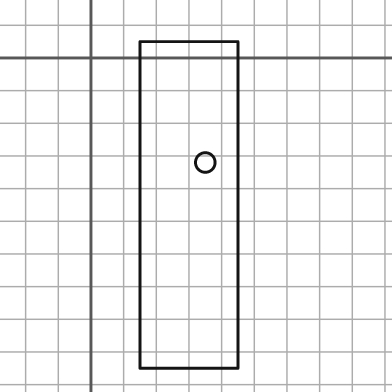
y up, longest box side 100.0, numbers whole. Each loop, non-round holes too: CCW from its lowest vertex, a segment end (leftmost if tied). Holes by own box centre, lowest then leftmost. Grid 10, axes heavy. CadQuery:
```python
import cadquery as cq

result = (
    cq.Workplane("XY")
    .moveTo(15.0, -95.0)
    .lineTo(45.0, -95.0)
    .lineTo(45.0, 5.0)
    .lineTo(15.0, 5.0)
    .close()
    .moveTo(35.0, -32.0)
    .circle(3.0)
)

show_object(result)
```